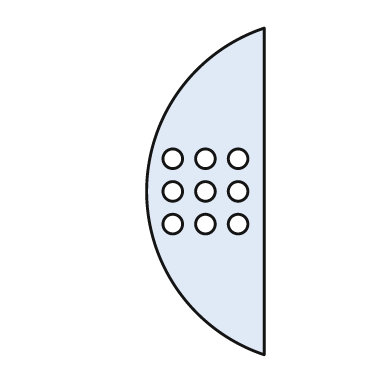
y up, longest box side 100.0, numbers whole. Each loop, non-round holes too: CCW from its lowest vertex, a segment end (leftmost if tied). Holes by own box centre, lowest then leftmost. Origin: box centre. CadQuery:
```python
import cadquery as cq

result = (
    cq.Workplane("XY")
    .moveTo(18.0, -50.0)
    .lineTo(18.0, 50.0)
    .threePointArc((-18.0, 0.0), (18.0, -50.0))
    .close()
    .moveTo(-10.0, -10.0)
    .circle(3.0)
    .moveTo(0.0, -10.0)
    .circle(3.0)
    .moveTo(10.0, -10.0)
    .circle(3.0)
    .moveTo(-10.0, 0.0)
    .circle(3.0)
    .moveTo(0.0, 0.0)
    .circle(3.0)
    .moveTo(10.0, 0.0)
    .circle(3.0)
    .moveTo(-10.0, 10.0)
    .circle(3.0)
    .moveTo(0.0, 10.0)
    .circle(3.0)
    .moveTo(10.0, 10.0)
    .circle(3.0)
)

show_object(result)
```